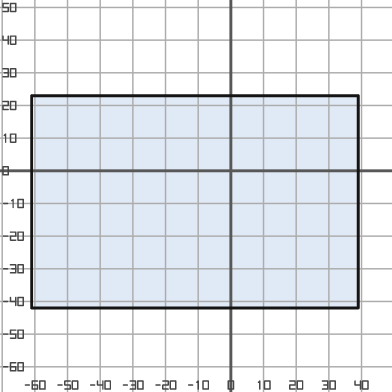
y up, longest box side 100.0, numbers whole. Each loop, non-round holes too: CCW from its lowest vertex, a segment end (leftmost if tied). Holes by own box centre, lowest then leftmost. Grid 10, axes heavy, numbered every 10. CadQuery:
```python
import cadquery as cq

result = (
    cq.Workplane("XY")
    .moveTo(-61.0, -42.0)
    .lineTo(39.0, -42.0)
    .lineTo(39.0, 23.0)
    .lineTo(-61.0, 23.0)
    .close()
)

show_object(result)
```